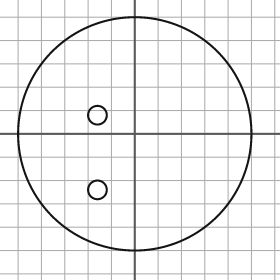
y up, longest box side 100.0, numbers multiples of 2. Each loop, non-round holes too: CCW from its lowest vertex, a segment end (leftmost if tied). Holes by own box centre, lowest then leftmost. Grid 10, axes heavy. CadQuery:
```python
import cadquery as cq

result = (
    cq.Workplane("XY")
    .moveTo(0.0, 0.0)
    .circle(50.0)
    .moveTo(-16.0, -24.0)
    .circle(4.0)
    .moveTo(-16.0, 8.0)
    .circle(4.0)
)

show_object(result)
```